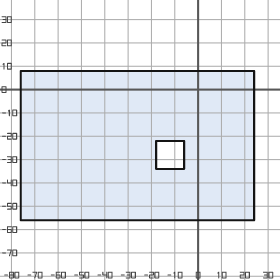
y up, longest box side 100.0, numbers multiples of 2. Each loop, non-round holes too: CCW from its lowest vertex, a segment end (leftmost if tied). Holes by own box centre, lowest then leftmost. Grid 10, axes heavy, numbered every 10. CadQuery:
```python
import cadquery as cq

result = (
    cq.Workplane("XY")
    .moveTo(-76.0, -56.0)
    .lineTo(24.0, -56.0)
    .lineTo(24.0, 8.0)
    .lineTo(-76.0, 8.0)
    .close()
    .moveTo(-18.0, -34.0)
    .lineTo(-6.0, -34.0)
    .lineTo(-6.0, -22.0)
    .lineTo(-18.0, -22.0)
    .close()
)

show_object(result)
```